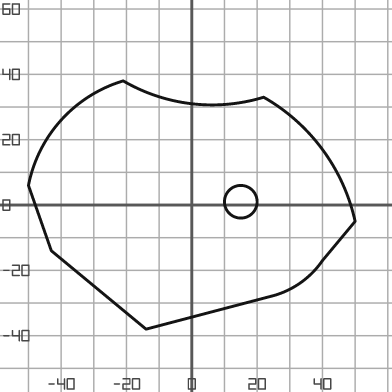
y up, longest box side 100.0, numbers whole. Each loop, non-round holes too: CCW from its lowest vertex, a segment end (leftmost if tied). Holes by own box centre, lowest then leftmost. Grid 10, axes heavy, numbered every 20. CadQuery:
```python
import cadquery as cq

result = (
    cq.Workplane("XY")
    .moveTo(-14.0, -38.0)
    .lineTo(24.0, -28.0)
    .threePointArc((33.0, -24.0), (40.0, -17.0))
    .lineTo(50.0, -5.0)
    .threePointArc((40.0, 17.0), (22.0, 33.0))
    .threePointArc((0.0, 31.0), (-21.0, 38.0))
    .threePointArc((-40.0, 26.0), (-50.0, 6.0))
    .lineTo(-43.0, -14.0)
    .close()
    .moveTo(15.0, 1.0)
    .circle(5.0)
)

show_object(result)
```